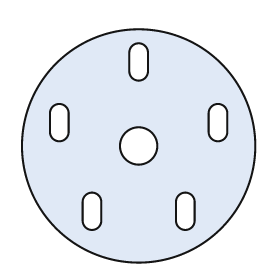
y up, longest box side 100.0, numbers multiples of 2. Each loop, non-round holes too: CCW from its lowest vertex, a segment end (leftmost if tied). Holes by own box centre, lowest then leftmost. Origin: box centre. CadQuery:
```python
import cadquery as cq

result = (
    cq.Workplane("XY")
    .moveTo(0.0, 0.0)
    .circle(50.0)
    .moveTo(-24.0, -32.0)
    .threePointArc((-20.0, -36.0), (-16.0, -32.0))
    .lineTo(-16.0, -24.0)
    .threePointArc((-20.0, -20.0), (-24.0, -24.0))
    .close()
    .moveTo(16.0, -32.0)
    .threePointArc((20.0, -36.0), (24.0, -32.0))
    .lineTo(24.0, -24.0)
    .threePointArc((20.0, -20.0), (16.0, -24.0))
    .close()
    .moveTo(0.0, 0.0)
    .circle(8.0)
    .moveTo(-38.0, 6.0)
    .threePointArc((-34.0, 2.0), (-30.0, 6.0))
    .lineTo(-30.0, 14.0)
    .threePointArc((-34.0, 18.0), (-38.0, 14.0))
    .close()
    .moveTo(30.0, 6.0)
    .threePointArc((34.0, 2.0), (38.0, 6.0))
    .lineTo(38.0, 14.0)
    .threePointArc((34.0, 18.0), (30.0, 14.0))
    .close()
    .moveTo(-4.0, 32.0)
    .threePointArc((0.0, 28.0), (4.0, 32.0))
    .lineTo(4.0, 40.0)
    .threePointArc((0.0, 44.0), (-4.0, 40.0))
    .close()
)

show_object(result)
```